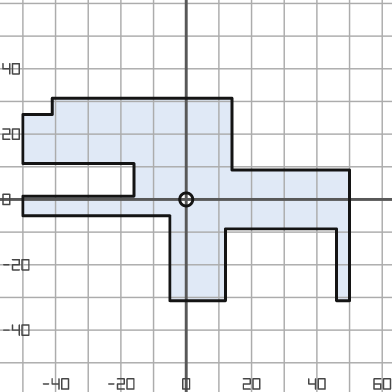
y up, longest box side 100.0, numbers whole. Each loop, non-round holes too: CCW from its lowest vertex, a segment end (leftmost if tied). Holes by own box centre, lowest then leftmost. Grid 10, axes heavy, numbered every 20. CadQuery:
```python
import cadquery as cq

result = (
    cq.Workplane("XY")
    .moveTo(-5.0, -31.0)
    .lineTo(12.0, -31.0)
    .lineTo(12.0, -9.0)
    .lineTo(46.0, -9.0)
    .lineTo(46.0, -31.0)
    .lineTo(50.0, -31.0)
    .lineTo(50.0, 9.0)
    .lineTo(14.0, 9.0)
    .lineTo(14.0, 31.0)
    .lineTo(-41.0, 31.0)
    .lineTo(-41.0, 26.0)
    .lineTo(-50.0, 26.0)
    .lineTo(-50.0, 11.0)
    .lineTo(-16.0, 11.0)
    .lineTo(-16.0, 1.0)
    .lineTo(-50.0, 1.0)
    .lineTo(-50.0, -5.0)
    .lineTo(-5.0, -5.0)
    .close()
    .moveTo(0.0, 0.0)
    .circle(2.0)
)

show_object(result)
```